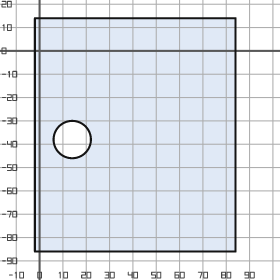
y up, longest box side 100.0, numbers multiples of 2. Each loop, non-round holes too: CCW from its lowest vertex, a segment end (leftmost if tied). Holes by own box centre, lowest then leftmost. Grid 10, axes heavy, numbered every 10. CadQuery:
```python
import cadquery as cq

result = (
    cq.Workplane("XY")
    .moveTo(-2.0, -86.0)
    .lineTo(84.0, -86.0)
    .lineTo(84.0, 14.0)
    .lineTo(-2.0, 14.0)
    .close()
    .moveTo(14.0, -38.0)
    .circle(8.0)
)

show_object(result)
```